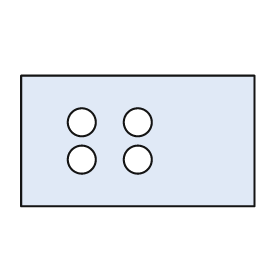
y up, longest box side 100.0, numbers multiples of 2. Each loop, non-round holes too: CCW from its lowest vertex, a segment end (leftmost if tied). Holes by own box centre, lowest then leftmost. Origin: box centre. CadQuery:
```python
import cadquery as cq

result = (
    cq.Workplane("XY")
    .moveTo(-50.0, -28.0)
    .lineTo(50.0, -28.0)
    .lineTo(50.0, 28.0)
    .lineTo(-50.0, 28.0)
    .close()
    .moveTo(-24.0, -8.0)
    .circle(6.0)
    .moveTo(0.0, -8.0)
    .circle(6.0)
    .moveTo(-24.0, 8.0)
    .circle(6.0)
    .moveTo(0.0, 8.0)
    .circle(6.0)
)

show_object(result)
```